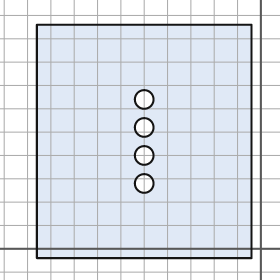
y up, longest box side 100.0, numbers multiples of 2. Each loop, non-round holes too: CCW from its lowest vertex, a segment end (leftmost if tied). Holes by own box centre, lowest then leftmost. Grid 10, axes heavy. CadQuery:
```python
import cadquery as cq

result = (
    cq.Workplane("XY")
    .moveTo(-96.0, -4.0)
    .lineTo(-4.0, -4.0)
    .lineTo(-4.0, 96.0)
    .lineTo(-96.0, 96.0)
    .close()
    .moveTo(-50.0, 28.0)
    .circle(4.0)
    .moveTo(-50.0, 40.0)
    .circle(4.0)
    .moveTo(-50.0, 52.0)
    .circle(4.0)
    .moveTo(-50.0, 64.0)
    .circle(4.0)
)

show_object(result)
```